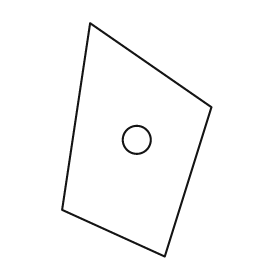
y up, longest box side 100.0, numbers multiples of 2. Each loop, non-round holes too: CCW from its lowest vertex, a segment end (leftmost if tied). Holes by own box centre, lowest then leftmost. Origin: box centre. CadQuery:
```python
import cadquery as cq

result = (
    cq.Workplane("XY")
    .moveTo(12.0, -50.0)
    .lineTo(32.0, 14.0)
    .lineTo(-20.0, 50.0)
    .lineTo(-32.0, -30.0)
    .close()
    .moveTo(0.0, 0.0)
    .circle(6.0)
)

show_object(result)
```